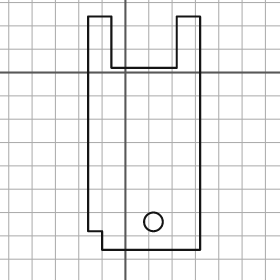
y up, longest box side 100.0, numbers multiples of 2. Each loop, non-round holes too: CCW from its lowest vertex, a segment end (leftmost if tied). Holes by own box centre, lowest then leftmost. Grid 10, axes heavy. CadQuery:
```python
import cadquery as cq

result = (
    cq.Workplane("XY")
    .moveTo(-10.0, -76.0)
    .lineTo(32.0, -76.0)
    .lineTo(32.0, 24.0)
    .lineTo(22.0, 24.0)
    .lineTo(22.0, 2.0)
    .lineTo(-6.0, 2.0)
    .lineTo(-6.0, 24.0)
    .lineTo(-16.0, 24.0)
    .lineTo(-16.0, -68.0)
    .lineTo(-10.0, -68.0)
    .close()
    .moveTo(12.0, -64.0)
    .circle(4.0)
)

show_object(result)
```